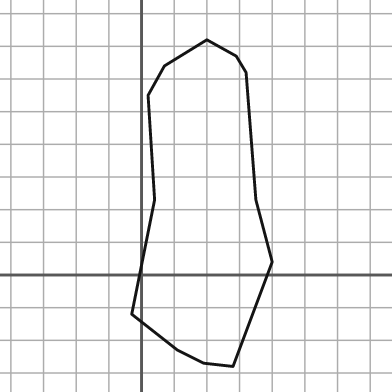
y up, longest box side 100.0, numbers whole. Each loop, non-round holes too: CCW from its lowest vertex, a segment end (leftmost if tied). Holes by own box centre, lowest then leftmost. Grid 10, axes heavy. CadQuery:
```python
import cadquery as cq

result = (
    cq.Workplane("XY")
    .moveTo(28.0, -28.0)
    .lineTo(40.0, 4.0)
    .lineTo(35.0, 23.0)
    .lineTo(32.0, 62.0)
    .lineTo(29.0, 67.0)
    .lineTo(20.0, 72.0)
    .lineTo(7.0, 64.0)
    .lineTo(2.0, 55.0)
    .lineTo(4.0, 23.0)
    .lineTo(-3.0, -12.0)
    .lineTo(11.0, -23.0)
    .lineTo(19.0, -27.0)
    .close()
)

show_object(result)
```